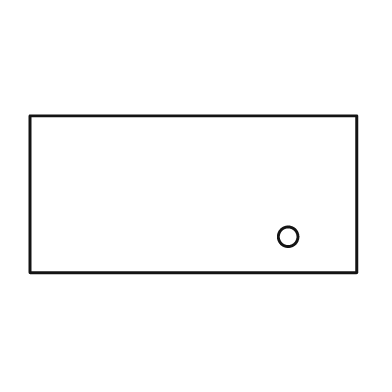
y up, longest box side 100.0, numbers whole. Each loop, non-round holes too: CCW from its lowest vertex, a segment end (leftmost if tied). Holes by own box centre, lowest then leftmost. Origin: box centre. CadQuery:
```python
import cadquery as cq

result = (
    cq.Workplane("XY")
    .moveTo(-50.0, -24.0)
    .lineTo(50.0, -24.0)
    .lineTo(50.0, 24.0)
    .lineTo(-50.0, 24.0)
    .close()
    .moveTo(29.0, -13.0)
    .circle(3.0)
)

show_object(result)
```